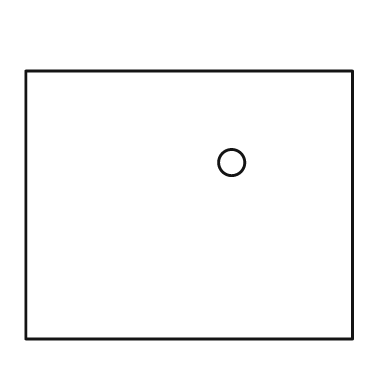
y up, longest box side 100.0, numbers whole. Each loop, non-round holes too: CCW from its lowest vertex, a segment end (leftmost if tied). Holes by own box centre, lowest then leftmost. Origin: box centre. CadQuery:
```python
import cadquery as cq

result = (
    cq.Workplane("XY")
    .moveTo(-50.0, -41.0)
    .lineTo(50.0, -41.0)
    .lineTo(50.0, 41.0)
    .lineTo(-50.0, 41.0)
    .close()
    .moveTo(13.0, 13.0)
    .circle(4.0)
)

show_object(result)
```